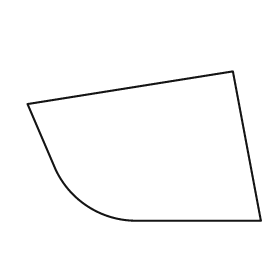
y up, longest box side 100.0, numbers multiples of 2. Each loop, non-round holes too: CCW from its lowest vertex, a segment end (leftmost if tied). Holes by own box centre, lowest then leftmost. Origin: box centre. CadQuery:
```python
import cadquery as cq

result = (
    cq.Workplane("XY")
    .moveTo(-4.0, -32.0)
    .lineTo(50.0, -32.0)
    .lineTo(38.0, 32.0)
    .lineTo(-50.0, 18.0)
    .lineTo(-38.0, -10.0)
    .threePointArc((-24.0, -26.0), (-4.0, -32.0))
    .close()
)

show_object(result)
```